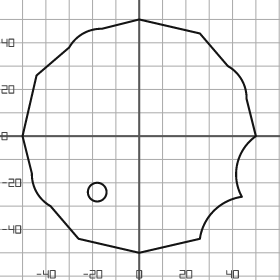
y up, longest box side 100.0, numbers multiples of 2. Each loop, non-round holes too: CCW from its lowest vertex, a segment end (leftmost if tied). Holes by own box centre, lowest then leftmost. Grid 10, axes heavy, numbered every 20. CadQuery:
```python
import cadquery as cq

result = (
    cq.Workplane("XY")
    .moveTo(0.0, -50.0)
    .lineTo(26.0, -44.0)
    .threePointArc((32.0, -32.0), (44.0, -26.0))
    .threePointArc((42.0, -12.0), (50.0, 0.0))
    .lineTo(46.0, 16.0)
    .threePointArc((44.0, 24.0), (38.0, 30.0))
    .lineTo(26.0, 44.0)
    .lineTo(0.0, 50.0)
    .lineTo(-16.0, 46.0)
    .threePointArc((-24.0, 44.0), (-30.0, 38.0))
    .lineTo(-44.0, 26.0)
    .lineTo(-50.0, 0.0)
    .lineTo(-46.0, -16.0)
    .threePointArc((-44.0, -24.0), (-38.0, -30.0))
    .lineTo(-26.0, -44.0)
    .close()
    .moveTo(-18.0, -24.0)
    .circle(4.0)
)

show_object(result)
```